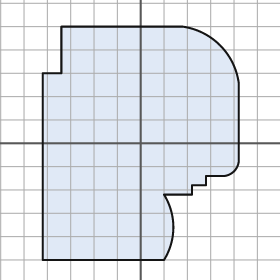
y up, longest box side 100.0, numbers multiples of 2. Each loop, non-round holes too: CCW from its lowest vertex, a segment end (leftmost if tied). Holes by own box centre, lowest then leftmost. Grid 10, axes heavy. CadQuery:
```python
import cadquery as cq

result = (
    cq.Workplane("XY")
    .moveTo(-42.0, -50.0)
    .lineTo(10.0, -50.0)
    .threePointArc((14.0, -36.0), (10.0, -22.0))
    .lineTo(22.0, -22.0)
    .lineTo(22.0, -18.0)
    .lineTo(28.0, -18.0)
    .lineTo(28.0, -14.0)
    .lineTo(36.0, -14.0)
    .threePointArc((40.0, -12.0), (42.0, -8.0))
    .lineTo(42.0, 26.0)
    .threePointArc((34.0, 42.0), (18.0, 50.0))
    .lineTo(-34.0, 50.0)
    .lineTo(-34.0, 30.0)
    .lineTo(-42.0, 30.0)
    .close()
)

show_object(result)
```